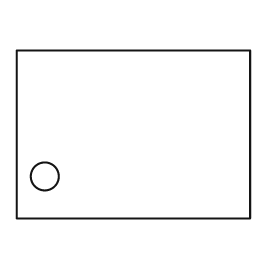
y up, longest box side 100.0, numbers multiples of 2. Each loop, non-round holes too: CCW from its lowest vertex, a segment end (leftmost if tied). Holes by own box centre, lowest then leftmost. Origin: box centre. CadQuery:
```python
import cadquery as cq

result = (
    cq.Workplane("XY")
    .moveTo(-50.0, -36.0)
    .lineTo(50.0, -36.0)
    .lineTo(50.0, 36.0)
    .lineTo(-50.0, 36.0)
    .close()
    .moveTo(-38.0, -18.0)
    .circle(6.0)
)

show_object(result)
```